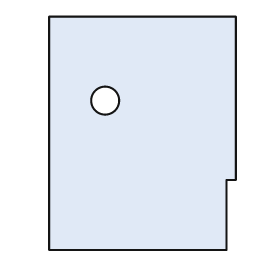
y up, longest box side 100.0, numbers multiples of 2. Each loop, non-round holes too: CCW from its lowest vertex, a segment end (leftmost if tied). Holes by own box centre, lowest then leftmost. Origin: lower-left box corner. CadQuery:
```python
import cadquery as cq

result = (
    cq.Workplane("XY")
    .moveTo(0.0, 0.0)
    .lineTo(76.0, 0.0)
    .lineTo(76.0, 30.0)
    .lineTo(80.0, 30.0)
    .lineTo(80.0, 100.0)
    .lineTo(0.0, 100.0)
    .close()
    .moveTo(24.0, 64.0)
    .circle(6.0)
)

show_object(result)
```